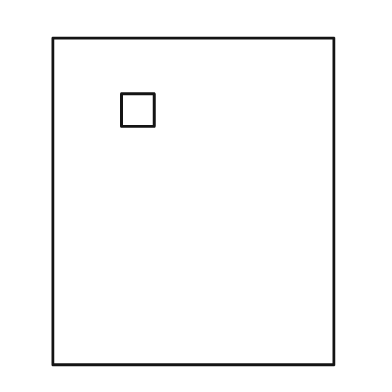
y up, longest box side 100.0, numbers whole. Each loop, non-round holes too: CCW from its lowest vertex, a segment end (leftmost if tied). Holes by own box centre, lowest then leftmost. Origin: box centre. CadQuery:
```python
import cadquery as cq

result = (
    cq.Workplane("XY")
    .moveTo(-43.0, -50.0)
    .lineTo(43.0, -50.0)
    .lineTo(43.0, 50.0)
    .lineTo(-43.0, 50.0)
    .close()
    .moveTo(-22.0, 23.0)
    .lineTo(-12.0, 23.0)
    .lineTo(-12.0, 33.0)
    .lineTo(-22.0, 33.0)
    .close()
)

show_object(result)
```